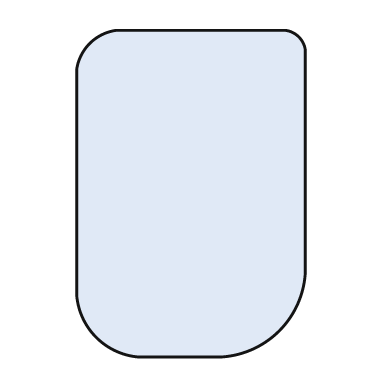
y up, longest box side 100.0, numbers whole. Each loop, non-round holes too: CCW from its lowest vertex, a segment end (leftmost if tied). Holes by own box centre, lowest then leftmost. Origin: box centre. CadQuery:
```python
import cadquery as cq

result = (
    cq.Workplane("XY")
    .moveTo(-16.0, -50.0)
    .lineTo(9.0, -50.0)
    .threePointArc((27.0, -42.0), (35.0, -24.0))
    .lineTo(35.0, 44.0)
    .threePointArc((33.0, 48.0), (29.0, 50.0))
    .lineTo(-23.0, 50.0)
    .threePointArc((-31.0, 46.0), (-35.0, 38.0))
    .lineTo(-35.0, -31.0)
    .threePointArc((-29.0, -44.0), (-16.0, -50.0))
    .close()
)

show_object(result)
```